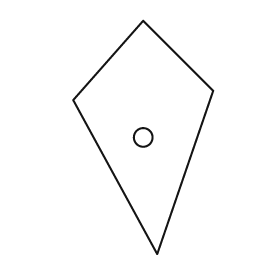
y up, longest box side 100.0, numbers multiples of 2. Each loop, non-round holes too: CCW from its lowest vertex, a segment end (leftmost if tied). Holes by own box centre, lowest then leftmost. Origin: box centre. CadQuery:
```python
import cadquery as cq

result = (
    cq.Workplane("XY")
    .moveTo(6.0, -50.0)
    .lineTo(30.0, 20.0)
    .lineTo(0.0, 50.0)
    .lineTo(-30.0, 16.0)
    .close()
    .moveTo(0.0, 0.0)
    .circle(4.0)
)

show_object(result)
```